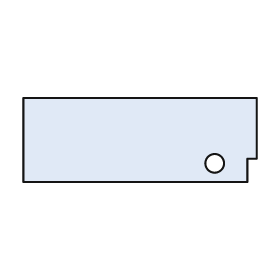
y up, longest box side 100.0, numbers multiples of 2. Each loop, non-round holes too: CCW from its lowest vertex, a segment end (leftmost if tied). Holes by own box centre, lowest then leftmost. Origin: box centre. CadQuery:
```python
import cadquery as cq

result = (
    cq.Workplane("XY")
    .moveTo(-50.0, -18.0)
    .lineTo(46.0, -18.0)
    .lineTo(46.0, -8.0)
    .lineTo(50.0, -8.0)
    .lineTo(50.0, 18.0)
    .lineTo(-50.0, 18.0)
    .close()
    .moveTo(32.0, -10.0)
    .circle(4.0)
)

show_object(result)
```